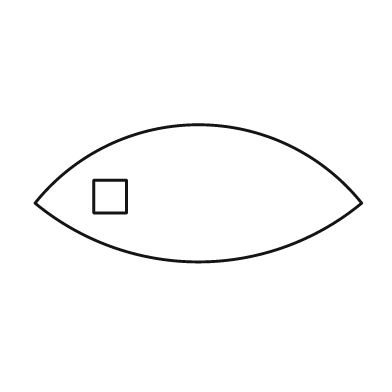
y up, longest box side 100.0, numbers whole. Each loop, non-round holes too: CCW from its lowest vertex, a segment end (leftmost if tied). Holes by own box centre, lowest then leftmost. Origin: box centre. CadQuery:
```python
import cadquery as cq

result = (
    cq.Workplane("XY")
    .moveTo(-50.0, -3.0)
    .threePointArc((0.0, -21.0), (50.0, -3.0))
    .threePointArc((0.0, 21.0), (-50.0, -3.0))
    .close()
    .moveTo(-32.0, -6.0)
    .lineTo(-22.0, -6.0)
    .lineTo(-22.0, 4.0)
    .lineTo(-32.0, 4.0)
    .close()
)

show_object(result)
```